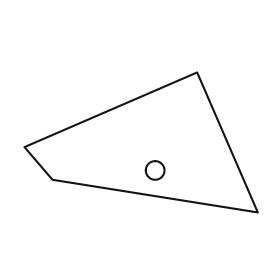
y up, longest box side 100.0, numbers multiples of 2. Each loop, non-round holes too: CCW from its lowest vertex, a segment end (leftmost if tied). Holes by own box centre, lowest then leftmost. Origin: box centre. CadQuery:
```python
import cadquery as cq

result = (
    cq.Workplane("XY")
    .moveTo(50.0, -30.0)
    .lineTo(24.0, 30.0)
    .lineTo(-50.0, -2.0)
    .lineTo(-38.0, -16.0)
    .close()
    .moveTo(6.0, -12.0)
    .circle(4.0)
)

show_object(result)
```